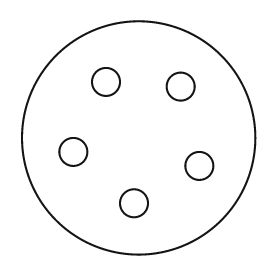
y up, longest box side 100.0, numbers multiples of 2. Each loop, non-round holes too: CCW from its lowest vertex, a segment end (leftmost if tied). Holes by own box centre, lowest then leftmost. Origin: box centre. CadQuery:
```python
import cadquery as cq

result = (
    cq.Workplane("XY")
    .moveTo(0.0, 0.0)
    .circle(50.0)
    .moveTo(-2.0, -28.0)
    .circle(6.0)
    .moveTo(26.0, -12.0)
    .circle(6.0)
    .moveTo(-28.0, -6.0)
    .circle(6.0)
    .moveTo(18.0, 22.0)
    .circle(6.0)
    .moveTo(-14.0, 24.0)
    .circle(6.0)
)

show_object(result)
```